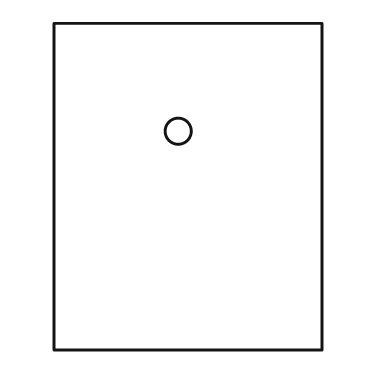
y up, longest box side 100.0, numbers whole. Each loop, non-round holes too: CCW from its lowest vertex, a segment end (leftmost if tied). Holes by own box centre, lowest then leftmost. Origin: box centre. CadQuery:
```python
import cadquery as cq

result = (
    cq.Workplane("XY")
    .moveTo(-41.0, -50.0)
    .lineTo(41.0, -50.0)
    .lineTo(41.0, 50.0)
    .lineTo(-41.0, 50.0)
    .close()
    .moveTo(-3.0, 17.0)
    .circle(4.0)
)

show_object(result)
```